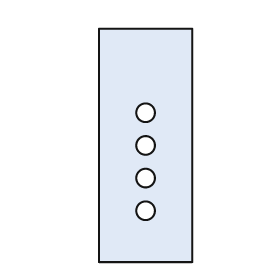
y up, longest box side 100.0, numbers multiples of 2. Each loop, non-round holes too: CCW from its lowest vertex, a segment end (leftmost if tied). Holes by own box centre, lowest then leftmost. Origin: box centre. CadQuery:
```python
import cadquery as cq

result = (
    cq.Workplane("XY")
    .moveTo(-20.0, -50.0)
    .lineTo(20.0, -50.0)
    .lineTo(20.0, 50.0)
    .lineTo(-20.0, 50.0)
    .close()
    .moveTo(0.0, -28.0)
    .circle(4.0)
    .moveTo(0.0, -14.0)
    .circle(4.0)
    .moveTo(0.0, 0.0)
    .circle(4.0)
    .moveTo(0.0, 14.0)
    .circle(4.0)
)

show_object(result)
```